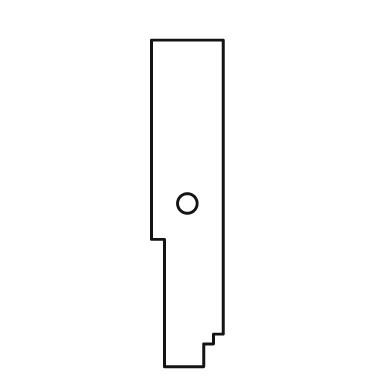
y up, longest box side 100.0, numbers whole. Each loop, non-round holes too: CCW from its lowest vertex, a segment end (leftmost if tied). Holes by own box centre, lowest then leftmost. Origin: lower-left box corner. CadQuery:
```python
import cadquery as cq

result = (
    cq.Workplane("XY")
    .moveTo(4.0, 0.0)
    .lineTo(16.0, 0.0)
    .lineTo(16.0, 7.0)
    .lineTo(19.0, 7.0)
    .lineTo(19.0, 10.0)
    .lineTo(22.0, 10.0)
    .lineTo(22.0, 100.0)
    .lineTo(0.0, 100.0)
    .lineTo(0.0, 39.0)
    .lineTo(4.0, 39.0)
    .close()
    .moveTo(11.0, 50.0)
    .circle(3.0)
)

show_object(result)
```